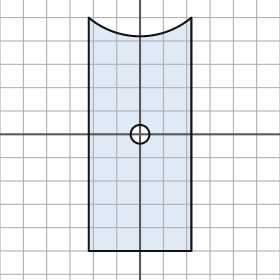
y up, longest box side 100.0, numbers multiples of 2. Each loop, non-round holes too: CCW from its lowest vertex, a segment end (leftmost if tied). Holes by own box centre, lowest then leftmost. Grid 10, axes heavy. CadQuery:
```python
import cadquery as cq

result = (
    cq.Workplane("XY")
    .moveTo(-22.0, -50.0)
    .lineTo(22.0, -50.0)
    .lineTo(22.0, 50.0)
    .threePointArc((0.0, 42.0), (-22.0, 50.0))
    .close()
    .moveTo(0.0, 0.0)
    .circle(4.0)
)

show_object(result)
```